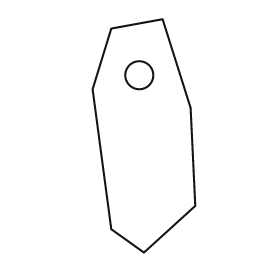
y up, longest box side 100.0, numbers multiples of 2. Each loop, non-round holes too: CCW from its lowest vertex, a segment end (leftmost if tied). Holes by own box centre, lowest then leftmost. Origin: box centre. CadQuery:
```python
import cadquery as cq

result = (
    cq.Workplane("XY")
    .moveTo(0.0, -50.0)
    .lineTo(22.0, -30.0)
    .lineTo(20.0, 12.0)
    .lineTo(8.0, 50.0)
    .lineTo(-14.0, 46.0)
    .lineTo(-22.0, 20.0)
    .lineTo(-14.0, -40.0)
    .close()
    .moveTo(-2.0, 26.0)
    .circle(6.0)
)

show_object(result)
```